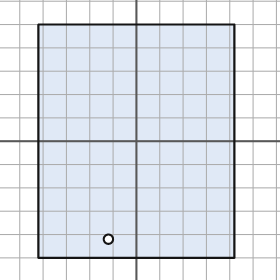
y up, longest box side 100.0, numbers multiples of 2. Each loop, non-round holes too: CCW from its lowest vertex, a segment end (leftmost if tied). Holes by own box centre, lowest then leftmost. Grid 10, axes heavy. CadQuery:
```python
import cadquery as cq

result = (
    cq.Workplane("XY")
    .moveTo(-42.0, -50.0)
    .lineTo(42.0, -50.0)
    .lineTo(42.0, 50.0)
    .lineTo(-42.0, 50.0)
    .close()
    .moveTo(-12.0, -42.0)
    .circle(2.0)
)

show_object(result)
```